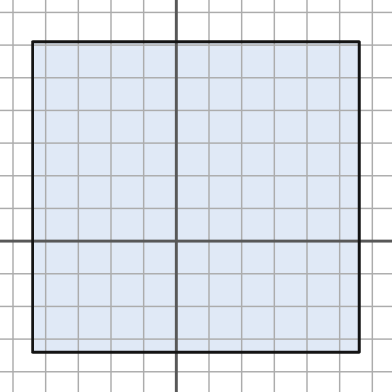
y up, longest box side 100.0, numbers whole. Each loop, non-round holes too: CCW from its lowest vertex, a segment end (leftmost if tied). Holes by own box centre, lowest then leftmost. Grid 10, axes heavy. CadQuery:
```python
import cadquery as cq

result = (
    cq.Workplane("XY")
    .moveTo(-44.0, -34.0)
    .lineTo(56.0, -34.0)
    .lineTo(56.0, 61.0)
    .lineTo(-44.0, 61.0)
    .close()
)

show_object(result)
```